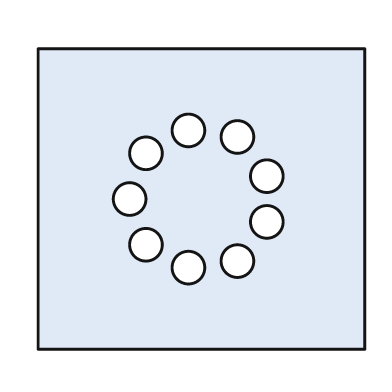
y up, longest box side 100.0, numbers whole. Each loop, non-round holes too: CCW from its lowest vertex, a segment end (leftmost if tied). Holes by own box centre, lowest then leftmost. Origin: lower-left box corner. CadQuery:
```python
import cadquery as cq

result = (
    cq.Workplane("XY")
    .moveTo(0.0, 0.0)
    .lineTo(100.0, 0.0)
    .lineTo(100.0, 92.0)
    .lineTo(0.0, 92.0)
    .close()
    .moveTo(46.0, 25.0)
    .circle(5.0)
    .moveTo(61.0, 27.0)
    .circle(5.0)
    .moveTo(33.0, 32.0)
    .circle(5.0)
    .moveTo(70.0, 39.0)
    .circle(5.0)
    .moveTo(28.0, 46.0)
    .circle(5.0)
    .moveTo(70.0, 53.0)
    .circle(5.0)
    .moveTo(33.0, 60.0)
    .circle(5.0)
    .moveTo(61.0, 65.0)
    .circle(5.0)
    .moveTo(46.0, 67.0)
    .circle(5.0)
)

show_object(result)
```